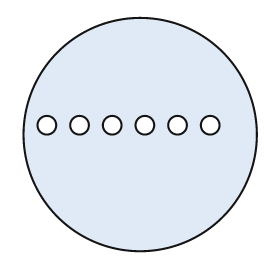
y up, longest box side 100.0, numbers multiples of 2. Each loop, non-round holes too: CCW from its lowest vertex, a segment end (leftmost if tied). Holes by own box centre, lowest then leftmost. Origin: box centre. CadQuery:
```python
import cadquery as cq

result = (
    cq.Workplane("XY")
    .moveTo(0.0, 0.0)
    .circle(50.0)
    .moveTo(-40.0, 4.0)
    .circle(4.0)
    .moveTo(-26.0, 4.0)
    .circle(4.0)
    .moveTo(-12.0, 4.0)
    .circle(4.0)
    .moveTo(2.0, 4.0)
    .circle(4.0)
    .moveTo(16.0, 4.0)
    .circle(4.0)
    .moveTo(30.0, 4.0)
    .circle(4.0)
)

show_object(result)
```